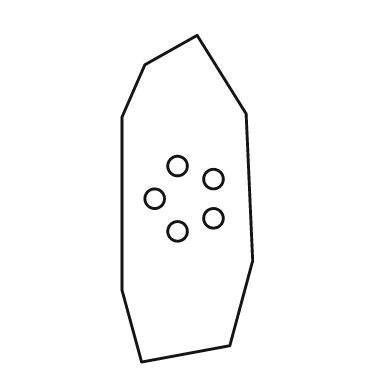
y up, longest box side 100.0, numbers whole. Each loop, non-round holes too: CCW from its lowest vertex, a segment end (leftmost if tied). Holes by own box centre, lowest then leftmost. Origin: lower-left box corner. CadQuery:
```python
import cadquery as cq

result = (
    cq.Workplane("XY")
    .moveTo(6.0, 0.0)
    .lineTo(33.0, 5.0)
    .lineTo(40.0, 31.0)
    .lineTo(38.0, 76.0)
    .lineTo(23.0, 100.0)
    .lineTo(7.0, 91.0)
    .lineTo(0.0, 75.0)
    .lineTo(0.0, 22.0)
    .close()
    .moveTo(17.0, 40.0)
    .circle(3.0)
    .moveTo(28.0, 44.0)
    .circle(3.0)
    .moveTo(10.0, 50.0)
    .circle(3.0)
    .moveTo(28.0, 56.0)
    .circle(3.0)
    .moveTo(17.0, 60.0)
    .circle(3.0)
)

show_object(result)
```